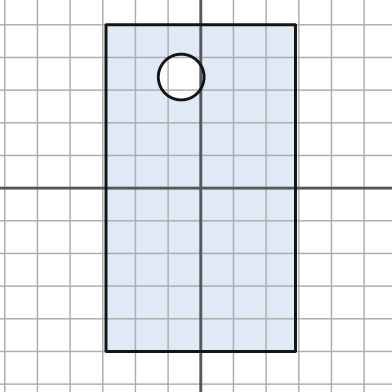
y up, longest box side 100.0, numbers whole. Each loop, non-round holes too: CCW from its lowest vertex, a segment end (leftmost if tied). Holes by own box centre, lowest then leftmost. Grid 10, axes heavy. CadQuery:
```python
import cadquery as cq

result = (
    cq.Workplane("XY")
    .moveTo(-29.0, -50.0)
    .lineTo(29.0, -50.0)
    .lineTo(29.0, 50.0)
    .lineTo(-29.0, 50.0)
    .close()
    .moveTo(-6.0, 34.0)
    .circle(7.0)
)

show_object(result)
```